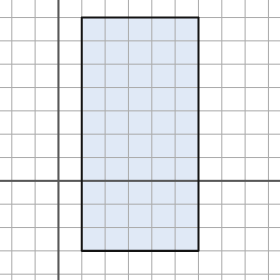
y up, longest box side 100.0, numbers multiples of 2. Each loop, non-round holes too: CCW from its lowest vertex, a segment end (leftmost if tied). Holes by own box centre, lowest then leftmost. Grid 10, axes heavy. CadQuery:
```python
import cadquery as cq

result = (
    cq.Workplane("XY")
    .moveTo(10.0, -30.0)
    .lineTo(60.0, -30.0)
    .lineTo(60.0, 70.0)
    .lineTo(10.0, 70.0)
    .close()
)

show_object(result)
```